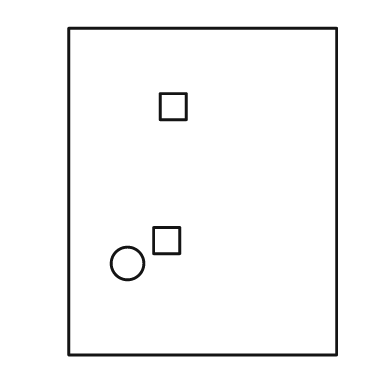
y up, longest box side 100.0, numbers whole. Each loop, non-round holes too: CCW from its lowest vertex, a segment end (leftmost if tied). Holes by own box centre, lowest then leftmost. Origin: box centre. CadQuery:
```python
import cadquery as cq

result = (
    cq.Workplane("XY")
    .moveTo(-41.0, -50.0)
    .lineTo(41.0, -50.0)
    .lineTo(41.0, 50.0)
    .lineTo(-41.0, 50.0)
    .close()
    .moveTo(-23.0, -22.0)
    .circle(5.0)
    .moveTo(-15.0, -19.0)
    .lineTo(-7.0, -19.0)
    .lineTo(-7.0, -11.0)
    .lineTo(-15.0, -11.0)
    .close()
    .moveTo(-13.0, 22.0)
    .lineTo(-5.0, 22.0)
    .lineTo(-5.0, 30.0)
    .lineTo(-13.0, 30.0)
    .close()
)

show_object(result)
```